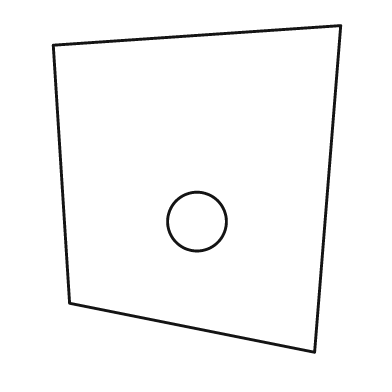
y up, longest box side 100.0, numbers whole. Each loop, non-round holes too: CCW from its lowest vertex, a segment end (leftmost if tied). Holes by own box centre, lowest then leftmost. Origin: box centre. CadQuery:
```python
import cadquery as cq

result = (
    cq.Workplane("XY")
    .moveTo(36.0, -50.0)
    .lineTo(44.0, 50.0)
    .lineTo(-44.0, 44.0)
    .lineTo(-39.0, -35.0)
    .close()
    .moveTo(0.0, -10.0)
    .circle(9.0)
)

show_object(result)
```